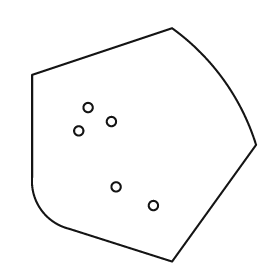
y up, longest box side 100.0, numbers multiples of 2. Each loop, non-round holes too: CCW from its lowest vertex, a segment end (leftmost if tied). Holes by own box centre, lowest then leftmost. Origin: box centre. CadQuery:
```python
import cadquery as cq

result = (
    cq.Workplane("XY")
    .moveTo(12.0, -50.0)
    .lineTo(48.0, 0.0)
    .threePointArc((34.0, 28.0), (12.0, 50.0))
    .lineTo(-48.0, 30.0)
    .lineTo(-48.0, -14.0)
    .threePointArc((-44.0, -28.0), (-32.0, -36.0))
    .close()
    .moveTo(4.0, -26.0)
    .circle(2.0)
    .moveTo(-12.0, -18.0)
    .circle(2.0)
    .moveTo(-28.0, 6.0)
    .circle(2.0)
    .moveTo(-14.0, 10.0)
    .circle(2.0)
    .moveTo(-24.0, 16.0)
    .circle(2.0)
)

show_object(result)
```